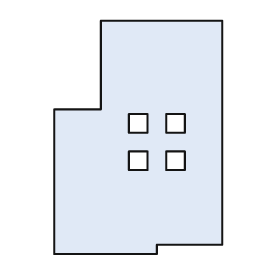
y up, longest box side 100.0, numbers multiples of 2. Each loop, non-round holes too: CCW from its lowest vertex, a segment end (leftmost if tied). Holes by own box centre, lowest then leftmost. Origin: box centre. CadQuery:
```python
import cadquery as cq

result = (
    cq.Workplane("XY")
    .moveTo(-36.0, -50.0)
    .lineTo(8.0, -50.0)
    .lineTo(8.0, -46.0)
    .lineTo(36.0, -46.0)
    .lineTo(36.0, 50.0)
    .lineTo(-16.0, 50.0)
    .lineTo(-16.0, 12.0)
    .lineTo(-36.0, 12.0)
    .close()
    .moveTo(-4.0, -14.0)
    .lineTo(4.0, -14.0)
    .lineTo(4.0, -6.0)
    .lineTo(-4.0, -6.0)
    .close()
    .moveTo(12.0, -14.0)
    .lineTo(20.0, -14.0)
    .lineTo(20.0, -6.0)
    .lineTo(12.0, -6.0)
    .close()
    .moveTo(-4.0, 2.0)
    .lineTo(4.0, 2.0)
    .lineTo(4.0, 10.0)
    .lineTo(-4.0, 10.0)
    .close()
    .moveTo(12.0, 2.0)
    .lineTo(20.0, 2.0)
    .lineTo(20.0, 10.0)
    .lineTo(12.0, 10.0)
    .close()
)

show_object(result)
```